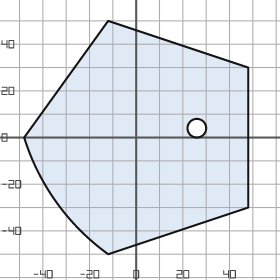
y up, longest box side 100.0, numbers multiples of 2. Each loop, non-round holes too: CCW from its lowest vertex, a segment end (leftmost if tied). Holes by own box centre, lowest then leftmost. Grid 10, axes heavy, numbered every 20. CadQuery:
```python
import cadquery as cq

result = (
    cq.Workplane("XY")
    .moveTo(-12.0, -50.0)
    .lineTo(48.0, -30.0)
    .lineTo(48.0, 30.0)
    .lineTo(-12.0, 50.0)
    .lineTo(-48.0, 0.0)
    .threePointArc((-34.0, -28.0), (-12.0, -50.0))
    .close()
    .moveTo(26.0, 4.0)
    .circle(4.0)
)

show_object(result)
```